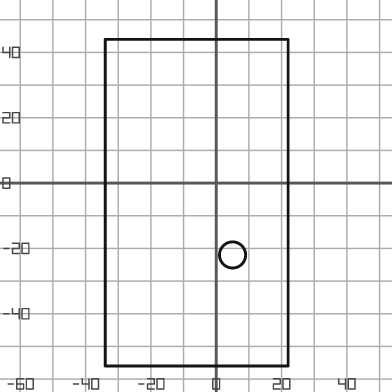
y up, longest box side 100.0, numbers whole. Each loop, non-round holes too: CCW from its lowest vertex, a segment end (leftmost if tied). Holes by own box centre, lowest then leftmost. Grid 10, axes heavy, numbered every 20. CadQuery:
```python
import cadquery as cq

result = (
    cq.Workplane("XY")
    .moveTo(-34.0, -56.0)
    .lineTo(22.0, -56.0)
    .lineTo(22.0, 44.0)
    .lineTo(-34.0, 44.0)
    .close()
    .moveTo(5.0, -22.0)
    .circle(4.0)
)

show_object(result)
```